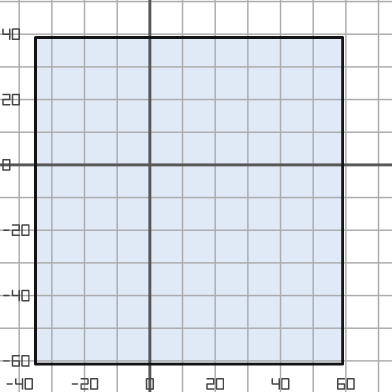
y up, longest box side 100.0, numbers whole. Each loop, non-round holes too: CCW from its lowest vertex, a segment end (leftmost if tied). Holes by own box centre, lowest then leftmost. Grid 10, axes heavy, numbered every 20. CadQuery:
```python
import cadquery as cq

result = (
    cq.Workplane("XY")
    .moveTo(-35.0, -61.0)
    .lineTo(59.0, -61.0)
    .lineTo(59.0, 39.0)
    .lineTo(-35.0, 39.0)
    .close()
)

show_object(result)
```